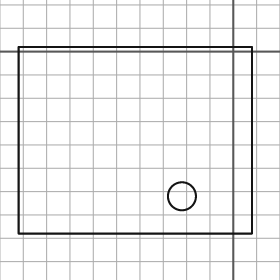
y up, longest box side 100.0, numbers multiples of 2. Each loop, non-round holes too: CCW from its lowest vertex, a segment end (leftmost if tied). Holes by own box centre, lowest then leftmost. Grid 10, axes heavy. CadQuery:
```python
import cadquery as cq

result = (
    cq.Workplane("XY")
    .moveTo(-92.0, -78.0)
    .lineTo(8.0, -78.0)
    .lineTo(8.0, 2.0)
    .lineTo(-92.0, 2.0)
    .close()
    .moveTo(-22.0, -62.0)
    .circle(6.0)
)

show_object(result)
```